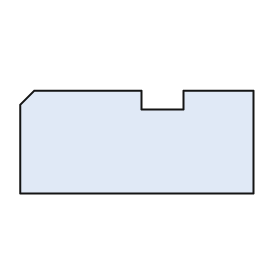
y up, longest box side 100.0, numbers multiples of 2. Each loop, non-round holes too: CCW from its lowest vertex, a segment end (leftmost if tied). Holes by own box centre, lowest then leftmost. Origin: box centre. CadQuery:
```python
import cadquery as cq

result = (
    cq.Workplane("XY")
    .moveTo(-50.0, -22.0)
    .lineTo(50.0, -22.0)
    .lineTo(50.0, 22.0)
    .lineTo(20.0, 22.0)
    .lineTo(20.0, 14.0)
    .lineTo(2.0, 14.0)
    .lineTo(2.0, 22.0)
    .lineTo(-44.0, 22.0)
    .lineTo(-50.0, 16.0)
    .close()
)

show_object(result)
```